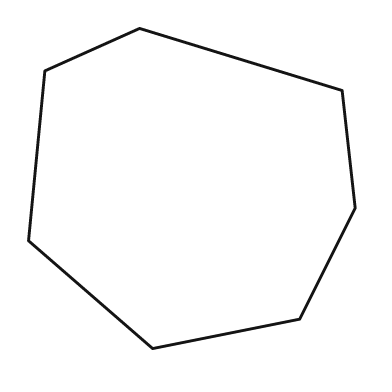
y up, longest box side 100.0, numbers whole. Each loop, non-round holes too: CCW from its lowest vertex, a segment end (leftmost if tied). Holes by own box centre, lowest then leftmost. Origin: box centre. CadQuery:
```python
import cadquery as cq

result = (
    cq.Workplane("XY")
    .moveTo(-12.0, -49.0)
    .lineTo(33.0, -40.0)
    .lineTo(50.0, -6.0)
    .lineTo(46.0, 30.0)
    .lineTo(-16.0, 49.0)
    .lineTo(-45.0, 36.0)
    .lineTo(-50.0, -16.0)
    .close()
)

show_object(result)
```